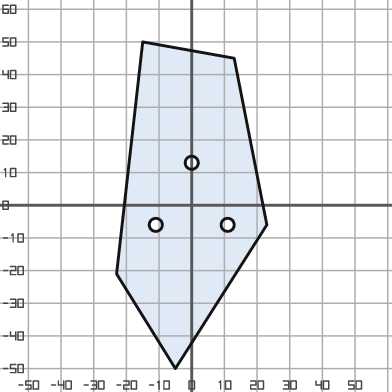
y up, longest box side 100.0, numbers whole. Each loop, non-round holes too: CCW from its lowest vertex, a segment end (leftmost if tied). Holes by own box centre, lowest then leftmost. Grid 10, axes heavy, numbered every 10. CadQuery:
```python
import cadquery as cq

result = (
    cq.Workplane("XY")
    .moveTo(-5.0, -50.0)
    .lineTo(23.0, -6.0)
    .lineTo(13.0, 45.0)
    .lineTo(-15.0, 50.0)
    .lineTo(-23.0, -21.0)
    .close()
    .moveTo(-11.0, -6.0)
    .circle(2.0)
    .moveTo(11.0, -6.0)
    .circle(2.0)
    .moveTo(0.0, 13.0)
    .circle(2.0)
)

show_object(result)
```